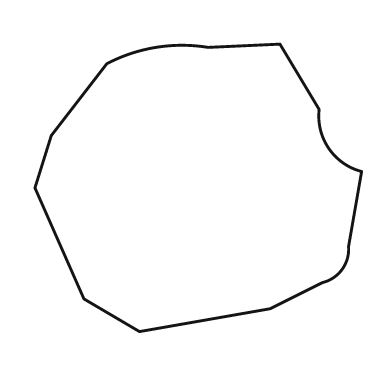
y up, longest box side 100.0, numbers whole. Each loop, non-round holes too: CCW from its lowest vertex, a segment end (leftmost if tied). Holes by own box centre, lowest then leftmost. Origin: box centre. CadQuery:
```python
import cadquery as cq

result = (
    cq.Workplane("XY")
    .moveTo(-18.0, -44.0)
    .lineTo(22.0, -37.0)
    .lineTo(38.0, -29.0)
    .threePointArc((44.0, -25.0), (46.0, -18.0))
    .lineTo(50.0, 5.0)
    .threePointArc((40.0, 12.0), (37.0, 24.0))
    .lineTo(25.0, 44.0)
    .lineTo(3.0, 43.0)
    .threePointArc((-13.0, 43.0), (-28.0, 38.0))
    .lineTo(-45.0, 16.0)
    .lineTo(-50.0, 0.0)
    .lineTo(-35.0, -34.0)
    .close()
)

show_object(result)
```